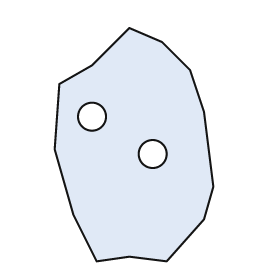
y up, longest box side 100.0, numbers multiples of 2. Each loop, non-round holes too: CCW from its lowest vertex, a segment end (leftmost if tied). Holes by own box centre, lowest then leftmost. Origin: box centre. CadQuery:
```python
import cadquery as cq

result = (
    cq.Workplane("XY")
    .moveTo(-16.0, -50.0)
    .lineTo(-2.0, -48.0)
    .lineTo(14.0, -50.0)
    .lineTo(30.0, -32.0)
    .lineTo(34.0, -18.0)
    .lineTo(30.0, 14.0)
    .lineTo(24.0, 32.0)
    .lineTo(12.0, 44.0)
    .lineTo(-2.0, 50.0)
    .lineTo(-18.0, 34.0)
    .lineTo(-32.0, 26.0)
    .lineTo(-34.0, -2.0)
    .lineTo(-26.0, -30.0)
    .close()
    .moveTo(8.0, -4.0)
    .circle(6.0)
    .moveTo(-18.0, 12.0)
    .circle(6.0)
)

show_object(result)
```